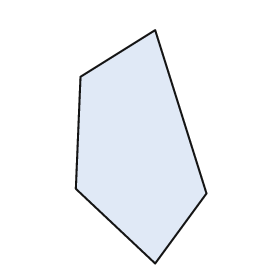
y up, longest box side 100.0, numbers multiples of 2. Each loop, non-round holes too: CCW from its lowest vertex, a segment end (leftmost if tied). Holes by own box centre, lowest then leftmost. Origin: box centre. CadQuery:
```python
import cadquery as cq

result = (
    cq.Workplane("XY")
    .moveTo(6.0, -50.0)
    .lineTo(28.0, -20.0)
    .lineTo(6.0, 50.0)
    .lineTo(-26.0, 30.0)
    .lineTo(-28.0, -18.0)
    .close()
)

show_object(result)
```